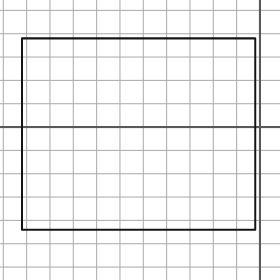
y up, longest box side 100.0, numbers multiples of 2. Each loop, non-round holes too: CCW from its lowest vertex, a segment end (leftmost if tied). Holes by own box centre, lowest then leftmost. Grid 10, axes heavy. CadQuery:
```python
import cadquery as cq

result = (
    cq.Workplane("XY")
    .moveTo(-102.0, -44.0)
    .lineTo(-2.0, -44.0)
    .lineTo(-2.0, 38.0)
    .lineTo(-102.0, 38.0)
    .close()
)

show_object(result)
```